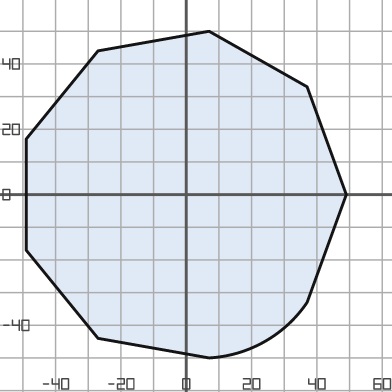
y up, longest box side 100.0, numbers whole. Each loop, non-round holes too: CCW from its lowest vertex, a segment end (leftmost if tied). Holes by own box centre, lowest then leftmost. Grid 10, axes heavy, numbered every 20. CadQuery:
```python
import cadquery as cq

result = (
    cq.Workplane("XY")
    .moveTo(7.0, -50.0)
    .threePointArc((24.0, -45.0), (37.0, -33.0))
    .lineTo(49.0, 0.0)
    .lineTo(37.0, 33.0)
    .lineTo(7.0, 50.0)
    .lineTo(-27.0, 44.0)
    .lineTo(-49.0, 17.0)
    .lineTo(-49.0, -17.0)
    .lineTo(-27.0, -44.0)
    .close()
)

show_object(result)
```